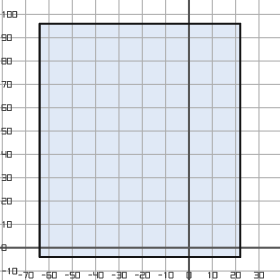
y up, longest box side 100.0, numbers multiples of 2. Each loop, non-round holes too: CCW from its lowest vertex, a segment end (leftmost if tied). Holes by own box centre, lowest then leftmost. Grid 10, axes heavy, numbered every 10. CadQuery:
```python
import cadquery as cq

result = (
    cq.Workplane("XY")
    .moveTo(-64.0, -4.0)
    .lineTo(22.0, -4.0)
    .lineTo(22.0, 96.0)
    .lineTo(-64.0, 96.0)
    .close()
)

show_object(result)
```